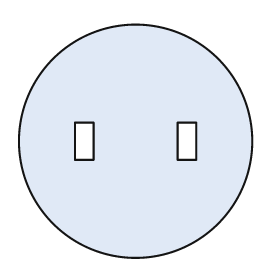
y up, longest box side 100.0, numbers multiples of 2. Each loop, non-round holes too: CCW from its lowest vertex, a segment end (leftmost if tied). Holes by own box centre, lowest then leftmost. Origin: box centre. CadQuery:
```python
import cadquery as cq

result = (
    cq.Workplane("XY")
    .moveTo(0.0, 0.0)
    .circle(50.0)
    .moveTo(-26.0, -8.0)
    .lineTo(-18.0, -8.0)
    .lineTo(-18.0, 8.0)
    .lineTo(-26.0, 8.0)
    .close()
    .moveTo(18.0, -8.0)
    .lineTo(26.0, -8.0)
    .lineTo(26.0, 8.0)
    .lineTo(18.0, 8.0)
    .close()
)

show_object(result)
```